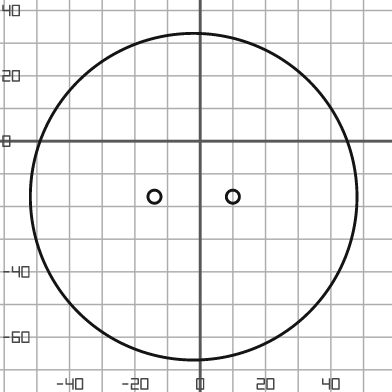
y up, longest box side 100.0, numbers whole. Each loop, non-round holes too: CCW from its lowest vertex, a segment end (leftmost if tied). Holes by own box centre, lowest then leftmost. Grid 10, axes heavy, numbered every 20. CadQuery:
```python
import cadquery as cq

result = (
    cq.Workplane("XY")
    .moveTo(-2.0, -17.0)
    .circle(50.0)
    .moveTo(-14.0, -17.0)
    .circle(2.0)
    .moveTo(10.0, -17.0)
    .circle(2.0)
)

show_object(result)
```